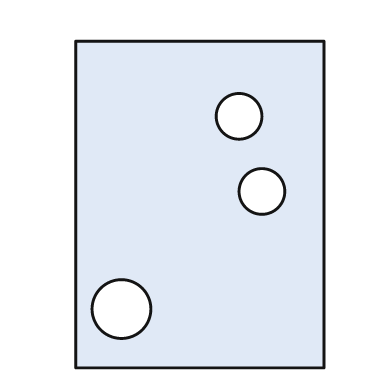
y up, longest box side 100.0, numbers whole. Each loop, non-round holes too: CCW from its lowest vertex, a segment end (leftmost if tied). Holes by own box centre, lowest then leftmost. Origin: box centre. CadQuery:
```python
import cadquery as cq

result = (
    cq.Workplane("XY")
    .moveTo(-38.0, -50.0)
    .lineTo(38.0, -50.0)
    .lineTo(38.0, 50.0)
    .lineTo(-38.0, 50.0)
    .close()
    .moveTo(-24.0, -32.0)
    .circle(9.0)
    .moveTo(19.0, 4.0)
    .circle(7.0)
    .moveTo(12.0, 27.0)
    .circle(7.0)
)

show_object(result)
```